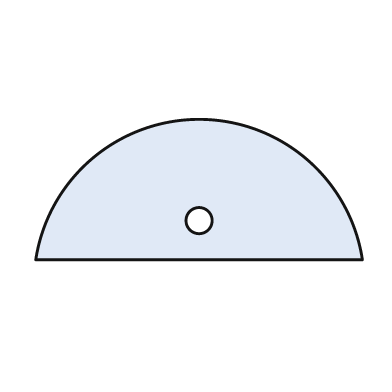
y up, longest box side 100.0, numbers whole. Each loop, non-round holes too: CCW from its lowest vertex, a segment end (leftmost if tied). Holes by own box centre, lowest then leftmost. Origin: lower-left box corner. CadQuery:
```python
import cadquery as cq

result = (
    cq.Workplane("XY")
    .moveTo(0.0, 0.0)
    .lineTo(100.0, 0.0)
    .threePointArc((50.0, 43.0), (0.0, 0.0))
    .close()
    .moveTo(50.0, 12.0)
    .circle(4.0)
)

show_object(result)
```